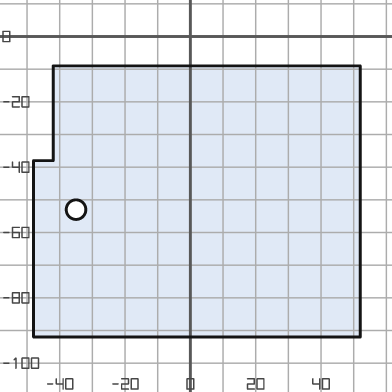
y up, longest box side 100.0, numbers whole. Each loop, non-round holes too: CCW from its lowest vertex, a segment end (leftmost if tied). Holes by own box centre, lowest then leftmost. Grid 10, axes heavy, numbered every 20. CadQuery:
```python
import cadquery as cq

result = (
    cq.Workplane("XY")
    .moveTo(-48.0, -92.0)
    .lineTo(52.0, -92.0)
    .lineTo(52.0, -9.0)
    .lineTo(-42.0, -9.0)
    .lineTo(-42.0, -38.0)
    .lineTo(-48.0, -38.0)
    .close()
    .moveTo(-35.0, -53.0)
    .circle(3.0)
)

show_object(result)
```